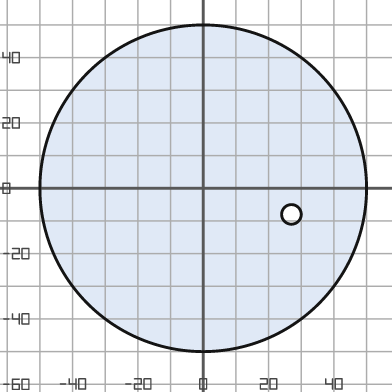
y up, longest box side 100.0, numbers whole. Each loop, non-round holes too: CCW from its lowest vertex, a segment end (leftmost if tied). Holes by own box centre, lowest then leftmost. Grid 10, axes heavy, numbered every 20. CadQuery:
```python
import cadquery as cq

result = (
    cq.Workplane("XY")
    .moveTo(0.0, 0.0)
    .circle(50.0)
    .moveTo(27.0, -8.0)
    .circle(3.0)
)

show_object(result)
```